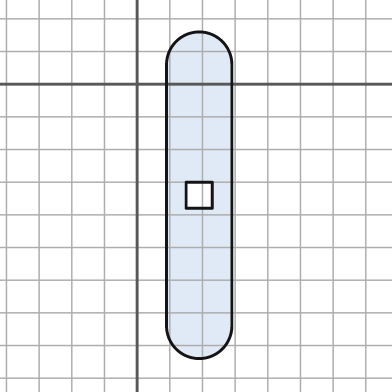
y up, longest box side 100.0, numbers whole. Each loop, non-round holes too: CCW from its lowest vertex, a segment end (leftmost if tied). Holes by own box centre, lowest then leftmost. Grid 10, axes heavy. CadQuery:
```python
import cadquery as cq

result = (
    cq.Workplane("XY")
    .moveTo(9.0, -74.0)
    .threePointArc((19.0, -84.0), (29.0, -74.0))
    .lineTo(29.0, 6.0)
    .threePointArc((19.0, 16.0), (9.0, 6.0))
    .close()
    .moveTo(15.0, -38.0)
    .lineTo(23.0, -38.0)
    .lineTo(23.0, -30.0)
    .lineTo(15.0, -30.0)
    .close()
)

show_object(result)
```